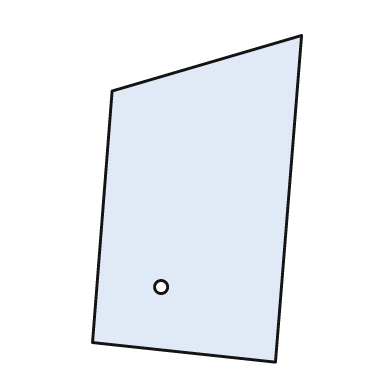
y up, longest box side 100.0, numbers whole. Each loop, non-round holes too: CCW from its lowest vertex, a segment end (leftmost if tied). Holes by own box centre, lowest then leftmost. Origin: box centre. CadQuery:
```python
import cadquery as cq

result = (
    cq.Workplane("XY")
    .moveTo(24.0, -50.0)
    .lineTo(32.0, 50.0)
    .lineTo(-26.0, 33.0)
    .lineTo(-32.0, -44.0)
    .close()
    .moveTo(-11.0, -27.0)
    .circle(2.0)
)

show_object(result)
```